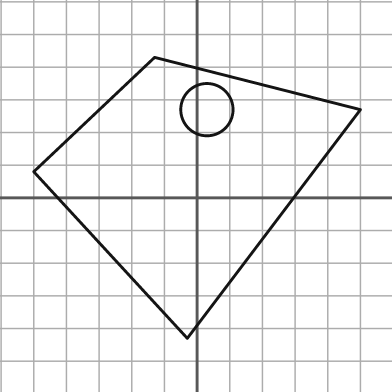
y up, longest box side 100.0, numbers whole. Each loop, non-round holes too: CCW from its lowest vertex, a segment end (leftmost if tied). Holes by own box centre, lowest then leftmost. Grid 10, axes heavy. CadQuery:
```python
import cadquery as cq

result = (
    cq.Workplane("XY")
    .moveTo(-3.0, -43.0)
    .lineTo(50.0, 27.0)
    .lineTo(-13.0, 43.0)
    .lineTo(-50.0, 8.0)
    .close()
    .moveTo(3.0, 27.0)
    .circle(8.0)
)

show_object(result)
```